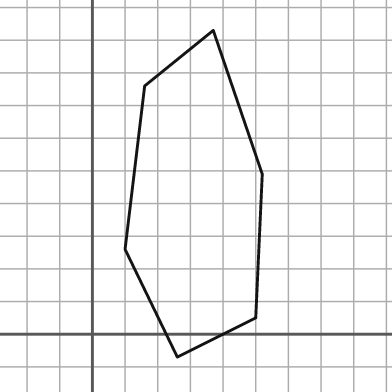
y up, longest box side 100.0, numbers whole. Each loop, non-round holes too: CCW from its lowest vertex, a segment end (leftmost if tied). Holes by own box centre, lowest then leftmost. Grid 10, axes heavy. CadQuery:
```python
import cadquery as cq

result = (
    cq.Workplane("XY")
    .moveTo(26.0, -7.0)
    .lineTo(50.0, 5.0)
    .lineTo(52.0, 49.0)
    .lineTo(37.0, 93.0)
    .lineTo(16.0, 76.0)
    .lineTo(10.0, 26.0)
    .close()
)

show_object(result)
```